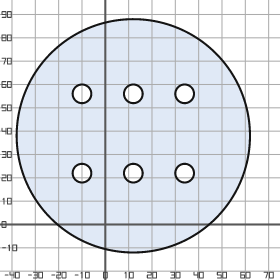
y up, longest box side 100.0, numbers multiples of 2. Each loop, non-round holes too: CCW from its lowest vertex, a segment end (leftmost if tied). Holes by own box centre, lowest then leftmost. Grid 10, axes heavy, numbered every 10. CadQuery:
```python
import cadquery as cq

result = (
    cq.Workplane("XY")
    .moveTo(12.0, 38.0)
    .circle(50.0)
    .moveTo(-10.0, 22.0)
    .circle(4.0)
    .moveTo(12.0, 22.0)
    .circle(4.0)
    .moveTo(34.0, 22.0)
    .circle(4.0)
    .moveTo(-10.0, 56.0)
    .circle(4.0)
    .moveTo(12.0, 56.0)
    .circle(4.0)
    .moveTo(34.0, 56.0)
    .circle(4.0)
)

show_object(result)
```